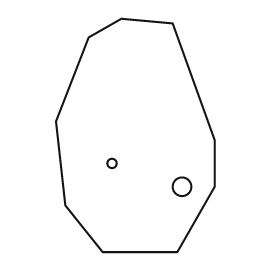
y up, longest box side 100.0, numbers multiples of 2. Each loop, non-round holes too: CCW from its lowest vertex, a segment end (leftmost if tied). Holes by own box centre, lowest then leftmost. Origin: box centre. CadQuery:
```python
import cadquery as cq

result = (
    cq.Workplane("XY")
    .moveTo(-14.0, -50.0)
    .lineTo(18.0, -50.0)
    .lineTo(34.0, -22.0)
    .lineTo(34.0, -2.0)
    .lineTo(16.0, 48.0)
    .lineTo(-6.0, 50.0)
    .lineTo(-20.0, 42.0)
    .lineTo(-34.0, 6.0)
    .lineTo(-30.0, -30.0)
    .close()
    .moveTo(20.0, -22.0)
    .circle(4.0)
    .moveTo(-10.0, -12.0)
    .circle(2.0)
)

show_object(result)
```